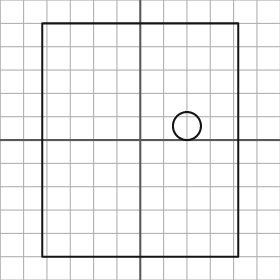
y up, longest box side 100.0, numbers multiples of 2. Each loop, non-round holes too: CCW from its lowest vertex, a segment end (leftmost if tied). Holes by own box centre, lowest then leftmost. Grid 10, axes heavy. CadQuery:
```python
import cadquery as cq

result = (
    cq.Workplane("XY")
    .moveTo(-42.0, -50.0)
    .lineTo(42.0, -50.0)
    .lineTo(42.0, 50.0)
    .lineTo(-42.0, 50.0)
    .close()
    .moveTo(20.0, 6.0)
    .circle(6.0)
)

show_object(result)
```